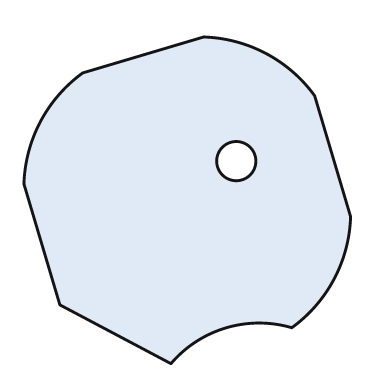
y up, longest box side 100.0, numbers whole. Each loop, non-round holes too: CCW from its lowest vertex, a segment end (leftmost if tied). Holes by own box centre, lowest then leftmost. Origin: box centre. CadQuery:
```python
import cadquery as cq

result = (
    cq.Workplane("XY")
    .moveTo(-5.0, -50.0)
    .threePointArc((12.0, -39.0), (32.0, -39.0))
    .threePointArc((45.0, -24.0), (50.0, -5.0))
    .lineTo(39.0, 32.0)
    .threePointArc((24.0, 45.0), (5.0, 50.0))
    .lineTo(-32.0, 39.0)
    .threePointArc((-45.0, 24.0), (-50.0, 5.0))
    .lineTo(-39.0, -32.0)
    .close()
    .moveTo(15.0, 12.0)
    .circle(6.0)
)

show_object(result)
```